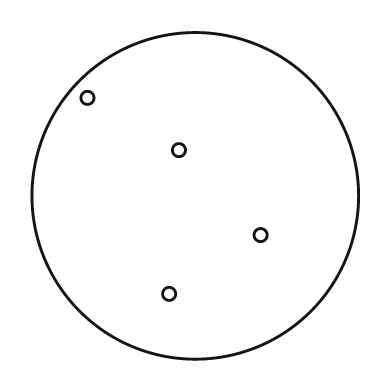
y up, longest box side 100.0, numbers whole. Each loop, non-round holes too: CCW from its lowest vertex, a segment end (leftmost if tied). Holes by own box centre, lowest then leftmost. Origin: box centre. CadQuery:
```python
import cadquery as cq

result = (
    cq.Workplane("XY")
    .moveTo(0.0, 0.0)
    .circle(50.0)
    .moveTo(-8.0, -30.0)
    .circle(2.0)
    .moveTo(20.0, -12.0)
    .circle(2.0)
    .moveTo(-5.0, 14.0)
    .circle(2.0)
    .moveTo(-33.0, 30.0)
    .circle(2.0)
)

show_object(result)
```